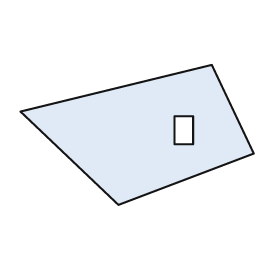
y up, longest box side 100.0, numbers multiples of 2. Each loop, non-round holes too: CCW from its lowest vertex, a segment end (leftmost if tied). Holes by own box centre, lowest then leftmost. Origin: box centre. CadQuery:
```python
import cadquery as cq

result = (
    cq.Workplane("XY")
    .moveTo(-8.0, -30.0)
    .lineTo(50.0, -8.0)
    .lineTo(32.0, 30.0)
    .lineTo(-50.0, 10.0)
    .close()
    .moveTo(16.0, -4.0)
    .lineTo(24.0, -4.0)
    .lineTo(24.0, 8.0)
    .lineTo(16.0, 8.0)
    .close()
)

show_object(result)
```